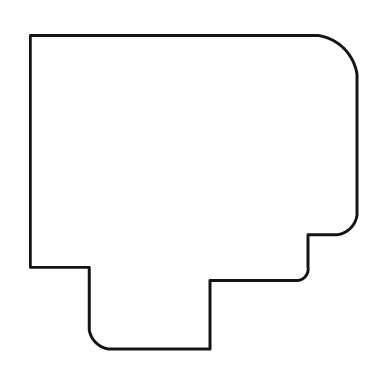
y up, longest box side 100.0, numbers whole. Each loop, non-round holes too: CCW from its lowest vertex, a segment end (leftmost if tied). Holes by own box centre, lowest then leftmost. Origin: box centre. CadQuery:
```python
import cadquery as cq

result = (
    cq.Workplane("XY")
    .moveTo(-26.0, -48.0)
    .lineTo(5.0, -48.0)
    .lineTo(5.0, -27.0)
    .lineTo(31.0, -27.0)
    .threePointArc((34.0, -26.0), (35.0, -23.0))
    .lineTo(35.0, -13.0)
    .lineTo(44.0, -13.0)
    .threePointArc((48.0, -11.0), (50.0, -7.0))
    .lineTo(50.0, 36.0)
    .threePointArc((46.0, 44.0), (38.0, 48.0))
    .lineTo(-50.0, 48.0)
    .lineTo(-50.0, -23.0)
    .lineTo(-32.0, -23.0)
    .lineTo(-32.0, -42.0)
    .threePointArc((-30.0, -46.0), (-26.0, -48.0))
    .close()
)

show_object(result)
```